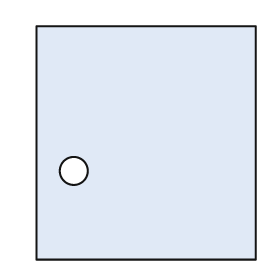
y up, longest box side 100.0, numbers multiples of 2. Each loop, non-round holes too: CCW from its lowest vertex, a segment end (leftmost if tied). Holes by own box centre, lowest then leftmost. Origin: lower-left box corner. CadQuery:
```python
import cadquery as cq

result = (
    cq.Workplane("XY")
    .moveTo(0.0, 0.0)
    .lineTo(94.0, 0.0)
    .lineTo(94.0, 100.0)
    .lineTo(0.0, 100.0)
    .close()
    .moveTo(16.0, 38.0)
    .circle(6.0)
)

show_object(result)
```